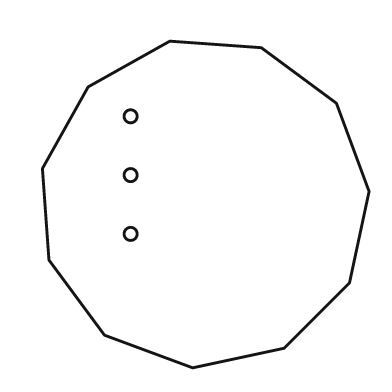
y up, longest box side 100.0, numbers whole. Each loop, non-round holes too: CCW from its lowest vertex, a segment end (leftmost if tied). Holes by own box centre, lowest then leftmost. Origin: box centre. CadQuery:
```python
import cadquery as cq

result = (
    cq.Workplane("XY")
    .moveTo(-4.0, -50.0)
    .lineTo(24.0, -44.0)
    .lineTo(44.0, -24.0)
    .lineTo(50.0, 4.0)
    .lineTo(40.0, 31.0)
    .lineTo(17.0, 48.0)
    .lineTo(-11.0, 50.0)
    .lineTo(-36.0, 36.0)
    .lineTo(-50.0, 11.0)
    .lineTo(-48.0, -17.0)
    .lineTo(-31.0, -40.0)
    .close()
    .moveTo(-23.0, -9.0)
    .circle(2.0)
    .moveTo(-23.0, 9.0)
    .circle(2.0)
    .moveTo(-23.0, 27.0)
    .circle(2.0)
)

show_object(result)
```